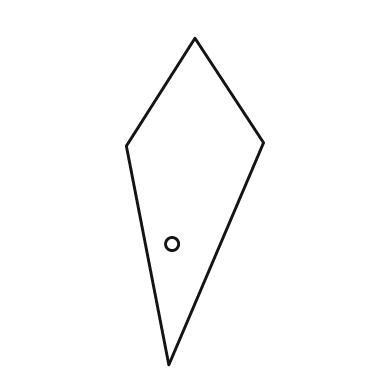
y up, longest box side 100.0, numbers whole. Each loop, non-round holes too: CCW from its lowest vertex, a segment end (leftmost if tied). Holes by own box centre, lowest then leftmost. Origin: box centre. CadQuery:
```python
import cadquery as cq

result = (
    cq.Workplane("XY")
    .moveTo(-8.0, -50.0)
    .lineTo(21.0, 18.0)
    .lineTo(0.0, 50.0)
    .lineTo(-21.0, 17.0)
    .close()
    .moveTo(-7.0, -13.0)
    .circle(2.0)
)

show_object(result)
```